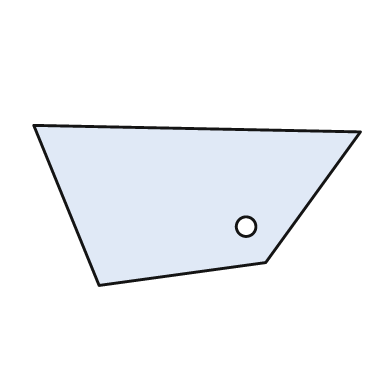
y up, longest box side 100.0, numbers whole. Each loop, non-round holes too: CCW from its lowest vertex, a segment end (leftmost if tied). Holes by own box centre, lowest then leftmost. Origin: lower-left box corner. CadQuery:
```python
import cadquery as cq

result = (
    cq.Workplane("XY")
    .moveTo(20.0, 0.0)
    .lineTo(71.0, 7.0)
    .lineTo(100.0, 47.0)
    .lineTo(0.0, 49.0)
    .close()
    .moveTo(65.0, 18.0)
    .circle(3.0)
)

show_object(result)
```